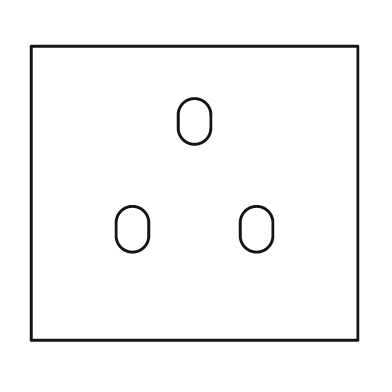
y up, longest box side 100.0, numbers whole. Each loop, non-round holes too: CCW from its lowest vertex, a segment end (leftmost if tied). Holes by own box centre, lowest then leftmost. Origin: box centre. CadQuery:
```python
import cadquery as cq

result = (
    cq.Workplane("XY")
    .moveTo(-50.0, -45.0)
    .lineTo(50.0, -45.0)
    .lineTo(50.0, 45.0)
    .lineTo(-50.0, 45.0)
    .close()
    .moveTo(-24.0, -13.0)
    .threePointArc((-19.0, -18.0), (-14.0, -13.0))
    .lineTo(-14.0, -9.0)
    .threePointArc((-19.0, -4.0), (-24.0, -9.0))
    .close()
    .moveTo(14.0, -13.0)
    .threePointArc((19.0, -18.0), (24.0, -13.0))
    .lineTo(24.0, -9.0)
    .threePointArc((19.0, -4.0), (14.0, -9.0))
    .close()
    .moveTo(-5.0, 20.0)
    .threePointArc((0.0, 15.0), (5.0, 20.0))
    .lineTo(5.0, 24.0)
    .threePointArc((0.0, 29.0), (-5.0, 24.0))
    .close()
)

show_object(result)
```